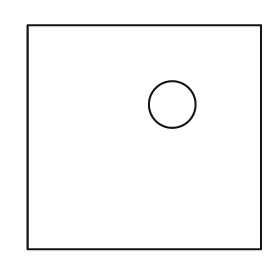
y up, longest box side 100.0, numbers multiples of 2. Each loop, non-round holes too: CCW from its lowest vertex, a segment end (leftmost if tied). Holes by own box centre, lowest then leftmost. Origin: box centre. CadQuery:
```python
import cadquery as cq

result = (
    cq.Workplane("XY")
    .moveTo(-50.0, -48.0)
    .lineTo(50.0, -48.0)
    .lineTo(50.0, 48.0)
    .lineTo(-50.0, 48.0)
    .close()
    .moveTo(12.0, 14.0)
    .circle(10.0)
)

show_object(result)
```